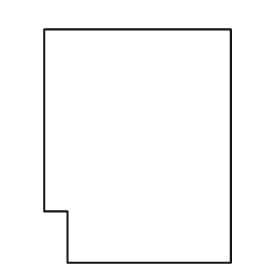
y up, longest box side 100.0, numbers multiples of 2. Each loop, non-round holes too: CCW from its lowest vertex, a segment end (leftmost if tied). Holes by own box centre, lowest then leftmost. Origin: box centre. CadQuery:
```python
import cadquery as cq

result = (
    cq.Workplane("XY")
    .moveTo(-30.0, -50.0)
    .lineTo(40.0, -50.0)
    .lineTo(40.0, 50.0)
    .lineTo(-40.0, 50.0)
    .lineTo(-40.0, -28.0)
    .lineTo(-30.0, -28.0)
    .close()
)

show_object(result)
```